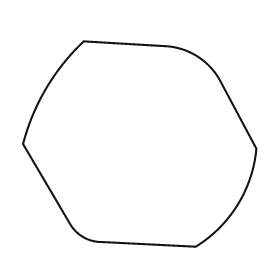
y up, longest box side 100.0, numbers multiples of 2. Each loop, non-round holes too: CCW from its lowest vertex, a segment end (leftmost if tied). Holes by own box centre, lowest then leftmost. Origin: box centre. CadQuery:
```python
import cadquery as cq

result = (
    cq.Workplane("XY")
    .moveTo(24.0, -44.0)
    .threePointArc((42.0, -26.0), (50.0, -2.0))
    .lineTo(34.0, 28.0)
    .threePointArc((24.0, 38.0), (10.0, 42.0))
    .lineTo(-24.0, 44.0)
    .threePointArc((-40.0, 24.0), (-50.0, 0.0))
    .lineTo(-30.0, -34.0)
    .threePointArc((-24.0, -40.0), (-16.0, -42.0))
    .close()
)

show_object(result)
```